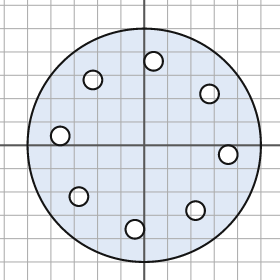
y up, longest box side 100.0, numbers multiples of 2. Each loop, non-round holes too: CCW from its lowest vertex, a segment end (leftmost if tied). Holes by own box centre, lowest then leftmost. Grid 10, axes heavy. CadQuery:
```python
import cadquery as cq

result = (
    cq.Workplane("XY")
    .moveTo(0.0, 0.0)
    .circle(50.0)
    .moveTo(-4.0, -36.0)
    .circle(4.0)
    .moveTo(22.0, -28.0)
    .circle(4.0)
    .moveTo(-28.0, -22.0)
    .circle(4.0)
    .moveTo(36.0, -4.0)
    .circle(4.0)
    .moveTo(-36.0, 4.0)
    .circle(4.0)
    .moveTo(28.0, 22.0)
    .circle(4.0)
    .moveTo(-22.0, 28.0)
    .circle(4.0)
    .moveTo(4.0, 36.0)
    .circle(4.0)
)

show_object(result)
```